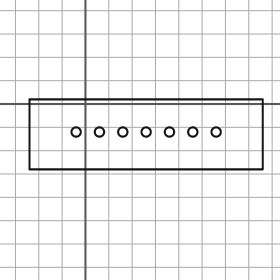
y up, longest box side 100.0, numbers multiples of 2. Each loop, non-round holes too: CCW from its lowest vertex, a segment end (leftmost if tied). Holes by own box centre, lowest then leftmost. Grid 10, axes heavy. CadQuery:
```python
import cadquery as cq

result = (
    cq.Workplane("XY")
    .moveTo(-24.0, -28.0)
    .lineTo(76.0, -28.0)
    .lineTo(76.0, 2.0)
    .lineTo(-24.0, 2.0)
    .close()
    .moveTo(-4.0, -12.0)
    .circle(2.0)
    .moveTo(6.0, -12.0)
    .circle(2.0)
    .moveTo(16.0, -12.0)
    .circle(2.0)
    .moveTo(26.0, -12.0)
    .circle(2.0)
    .moveTo(36.0, -12.0)
    .circle(2.0)
    .moveTo(46.0, -12.0)
    .circle(2.0)
    .moveTo(56.0, -12.0)
    .circle(2.0)
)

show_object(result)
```